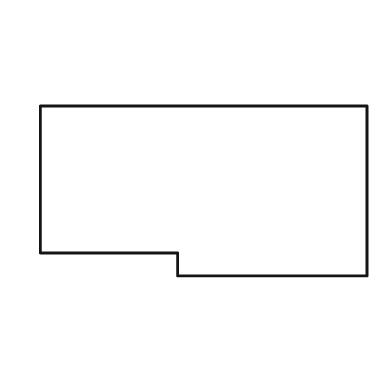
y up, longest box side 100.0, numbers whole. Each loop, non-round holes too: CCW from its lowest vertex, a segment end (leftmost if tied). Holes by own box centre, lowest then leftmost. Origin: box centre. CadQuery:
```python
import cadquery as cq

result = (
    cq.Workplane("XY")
    .moveTo(-8.0, -26.0)
    .lineTo(50.0, -26.0)
    .lineTo(50.0, 26.0)
    .lineTo(-50.0, 26.0)
    .lineTo(-50.0, -19.0)
    .lineTo(-8.0, -19.0)
    .close()
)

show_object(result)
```